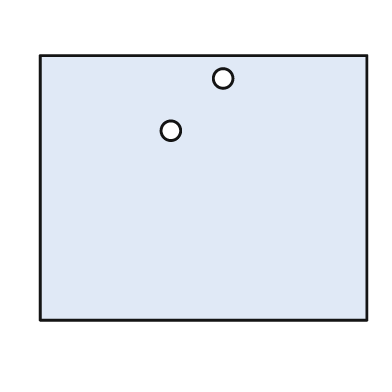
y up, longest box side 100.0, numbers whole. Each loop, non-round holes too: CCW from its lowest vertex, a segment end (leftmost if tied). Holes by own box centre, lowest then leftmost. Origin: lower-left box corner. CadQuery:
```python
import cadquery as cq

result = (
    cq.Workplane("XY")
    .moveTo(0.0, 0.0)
    .lineTo(100.0, 0.0)
    .lineTo(100.0, 81.0)
    .lineTo(0.0, 81.0)
    .close()
    .moveTo(40.0, 58.0)
    .circle(3.0)
    .moveTo(56.0, 74.0)
    .circle(3.0)
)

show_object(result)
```